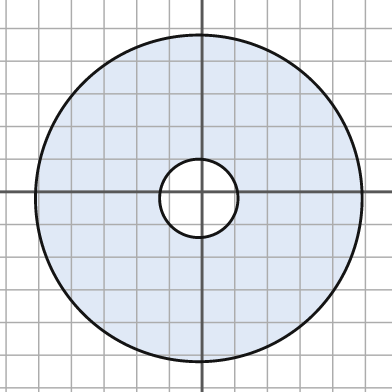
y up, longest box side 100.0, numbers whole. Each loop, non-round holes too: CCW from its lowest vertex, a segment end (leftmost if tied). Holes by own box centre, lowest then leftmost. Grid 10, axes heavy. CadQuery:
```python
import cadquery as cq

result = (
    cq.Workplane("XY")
    .moveTo(-1.0, -2.0)
    .circle(50.0)
    .moveTo(-1.0, -2.0)
    .circle(12.0)
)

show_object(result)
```